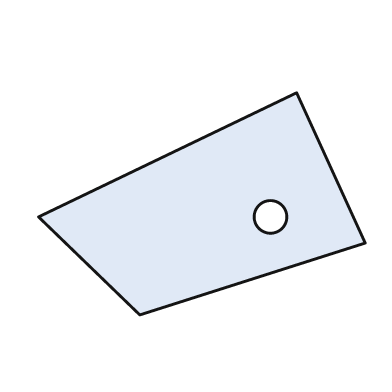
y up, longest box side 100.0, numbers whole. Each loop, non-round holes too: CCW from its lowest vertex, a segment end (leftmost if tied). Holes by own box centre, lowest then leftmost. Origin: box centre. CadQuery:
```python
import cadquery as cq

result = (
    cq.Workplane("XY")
    .moveTo(-19.0, -34.0)
    .lineTo(50.0, -12.0)
    .lineTo(29.0, 34.0)
    .lineTo(-50.0, -4.0)
    .close()
    .moveTo(21.0, -4.0)
    .circle(5.0)
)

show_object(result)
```